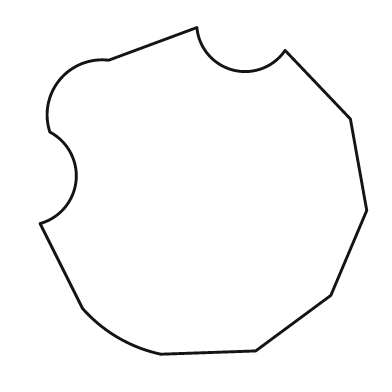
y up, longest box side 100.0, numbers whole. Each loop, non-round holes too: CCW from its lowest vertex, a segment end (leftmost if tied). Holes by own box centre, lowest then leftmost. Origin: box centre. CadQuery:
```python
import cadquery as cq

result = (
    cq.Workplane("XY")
    .moveTo(-13.0, -50.0)
    .lineTo(16.0, -49.0)
    .lineTo(39.0, -32.0)
    .lineTo(50.0, -6.0)
    .lineTo(45.0, 22.0)
    .lineTo(25.0, 43.0)
    .threePointArc((9.0, 37.0), (-2.0, 50.0))
    .lineTo(-29.0, 40.0)
    .threePointArc((-44.0, 34.0), (-47.0, 18.0))
    .threePointArc((-39.0, 3.0), (-50.0, -10.0))
    .lineTo(-37.0, -36.0)
    .threePointArc((-26.0, -45.0), (-13.0, -50.0))
    .close()
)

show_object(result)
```